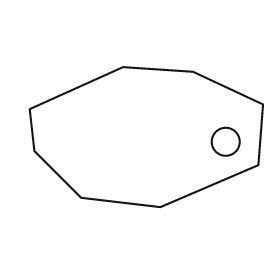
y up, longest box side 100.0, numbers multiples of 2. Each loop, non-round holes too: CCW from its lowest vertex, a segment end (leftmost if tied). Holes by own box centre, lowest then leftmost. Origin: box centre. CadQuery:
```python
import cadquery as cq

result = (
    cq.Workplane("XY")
    .moveTo(6.0, -30.0)
    .lineTo(48.0, -12.0)
    .lineTo(50.0, 14.0)
    .lineTo(20.0, 28.0)
    .lineTo(-10.0, 30.0)
    .lineTo(-50.0, 12.0)
    .lineTo(-48.0, -6.0)
    .lineTo(-28.0, -26.0)
    .close()
    .moveTo(34.0, -2.0)
    .circle(6.0)
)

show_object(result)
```